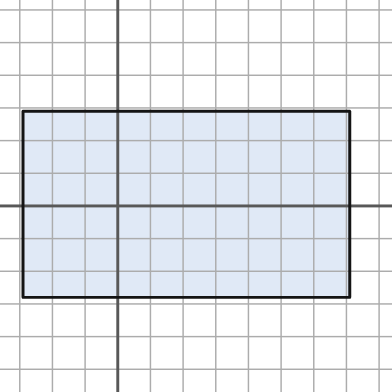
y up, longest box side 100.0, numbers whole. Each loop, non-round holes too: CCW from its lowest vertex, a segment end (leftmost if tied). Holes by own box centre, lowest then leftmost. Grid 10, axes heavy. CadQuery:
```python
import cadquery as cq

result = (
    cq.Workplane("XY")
    .moveTo(-29.0, -28.0)
    .lineTo(71.0, -28.0)
    .lineTo(71.0, 29.0)
    .lineTo(-29.0, 29.0)
    .close()
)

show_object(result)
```